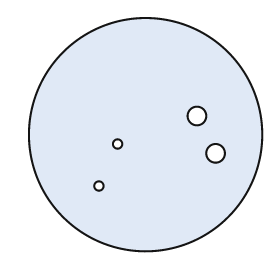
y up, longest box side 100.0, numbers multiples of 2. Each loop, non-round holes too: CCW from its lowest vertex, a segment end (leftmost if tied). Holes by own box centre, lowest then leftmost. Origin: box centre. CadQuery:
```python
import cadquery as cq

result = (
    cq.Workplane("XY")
    .moveTo(0.0, 0.0)
    .circle(50.0)
    .moveTo(-20.0, -22.0)
    .circle(2.0)
    .moveTo(30.0, -8.0)
    .circle(4.0)
    .moveTo(-12.0, -4.0)
    .circle(2.0)
    .moveTo(22.0, 8.0)
    .circle(4.0)
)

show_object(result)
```